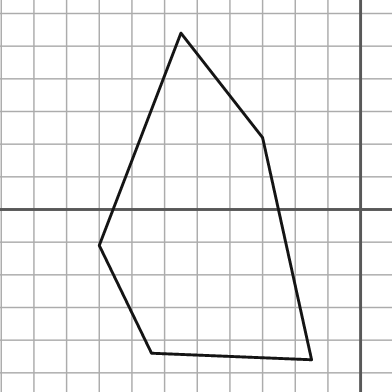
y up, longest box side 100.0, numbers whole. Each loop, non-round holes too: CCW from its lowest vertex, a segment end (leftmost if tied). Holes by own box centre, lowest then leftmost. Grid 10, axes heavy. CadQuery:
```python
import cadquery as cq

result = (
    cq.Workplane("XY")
    .moveTo(-15.0, -46.0)
    .lineTo(-30.0, 22.0)
    .lineTo(-55.0, 54.0)
    .lineTo(-80.0, -11.0)
    .lineTo(-64.0, -44.0)
    .close()
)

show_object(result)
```